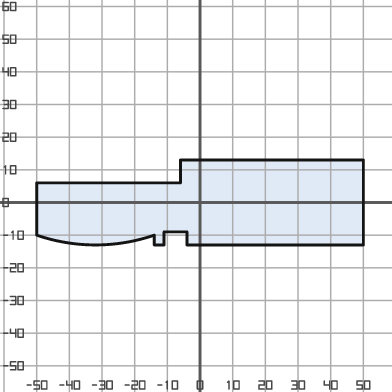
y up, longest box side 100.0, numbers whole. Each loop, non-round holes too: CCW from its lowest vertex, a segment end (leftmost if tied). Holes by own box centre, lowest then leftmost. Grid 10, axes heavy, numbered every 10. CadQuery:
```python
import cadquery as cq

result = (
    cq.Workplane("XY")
    .moveTo(-14.0, -13.0)
    .lineTo(-11.0, -13.0)
    .lineTo(-11.0, -9.0)
    .lineTo(-4.0, -9.0)
    .lineTo(-4.0, -13.0)
    .lineTo(50.0, -13.0)
    .lineTo(50.0, 13.0)
    .lineTo(-6.0, 13.0)
    .lineTo(-6.0, 6.0)
    .lineTo(-50.0, 6.0)
    .lineTo(-50.0, -10.0)
    .threePointArc((-32.0, -13.0), (-14.0, -10.0))
    .close()
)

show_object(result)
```